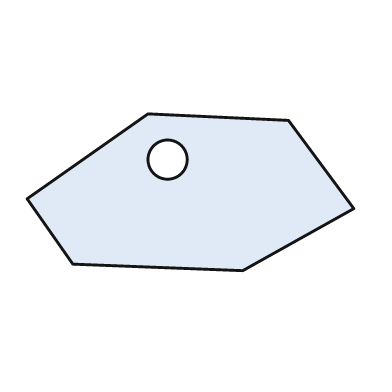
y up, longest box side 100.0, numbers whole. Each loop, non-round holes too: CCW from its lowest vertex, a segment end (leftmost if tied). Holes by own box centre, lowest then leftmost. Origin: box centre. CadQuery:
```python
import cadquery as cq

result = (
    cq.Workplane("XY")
    .moveTo(16.0, -24.0)
    .lineTo(50.0, -5.0)
    .lineTo(30.0, 22.0)
    .lineTo(-13.0, 24.0)
    .lineTo(-50.0, -2.0)
    .lineTo(-36.0, -22.0)
    .close()
    .moveTo(-7.0, 10.0)
    .circle(6.0)
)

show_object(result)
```